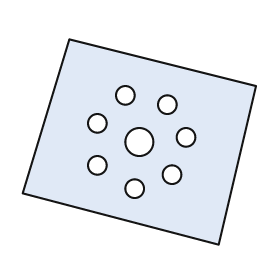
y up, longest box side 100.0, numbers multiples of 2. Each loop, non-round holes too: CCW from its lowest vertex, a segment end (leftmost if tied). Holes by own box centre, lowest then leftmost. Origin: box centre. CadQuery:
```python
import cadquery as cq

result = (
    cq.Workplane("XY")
    .moveTo(34.0, -44.0)
    .lineTo(50.0, 24.0)
    .lineTo(-30.0, 44.0)
    .lineTo(-50.0, -22.0)
    .close()
    .moveTo(-2.0, -20.0)
    .circle(4.0)
    .moveTo(14.0, -14.0)
    .circle(4.0)
    .moveTo(-18.0, -10.0)
    .circle(4.0)
    .moveTo(0.0, 0.0)
    .circle(6.0)
    .moveTo(20.0, 2.0)
    .circle(4.0)
    .moveTo(-18.0, 8.0)
    .circle(4.0)
    .moveTo(12.0, 16.0)
    .circle(4.0)
    .moveTo(-6.0, 20.0)
    .circle(4.0)
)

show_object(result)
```